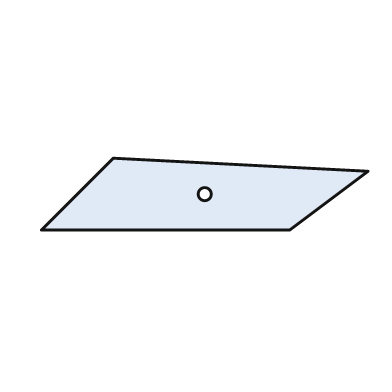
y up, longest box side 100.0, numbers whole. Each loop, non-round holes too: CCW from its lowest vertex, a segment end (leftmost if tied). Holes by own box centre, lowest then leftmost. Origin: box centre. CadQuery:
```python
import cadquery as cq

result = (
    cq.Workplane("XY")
    .moveTo(-50.0, -11.0)
    .lineTo(26.0, -11.0)
    .lineTo(50.0, 7.0)
    .lineTo(-28.0, 11.0)
    .close()
    .moveTo(0.0, 0.0)
    .circle(2.0)
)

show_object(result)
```